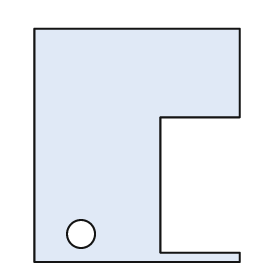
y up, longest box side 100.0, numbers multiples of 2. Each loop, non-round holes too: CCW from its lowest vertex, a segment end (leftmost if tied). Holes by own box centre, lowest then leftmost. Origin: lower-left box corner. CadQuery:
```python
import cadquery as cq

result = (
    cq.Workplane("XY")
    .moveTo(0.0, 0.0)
    .lineTo(88.0, 0.0)
    .lineTo(88.0, 4.0)
    .lineTo(54.0, 4.0)
    .lineTo(54.0, 62.0)
    .lineTo(88.0, 62.0)
    .lineTo(88.0, 100.0)
    .lineTo(0.0, 100.0)
    .close()
    .moveTo(20.0, 12.0)
    .circle(6.0)
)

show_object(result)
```